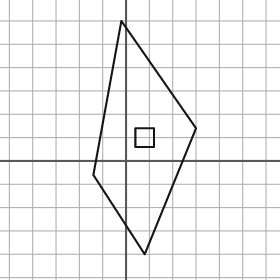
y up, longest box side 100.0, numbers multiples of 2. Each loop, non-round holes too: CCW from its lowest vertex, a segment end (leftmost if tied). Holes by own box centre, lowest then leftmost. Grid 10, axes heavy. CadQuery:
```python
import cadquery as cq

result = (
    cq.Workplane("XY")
    .moveTo(8.0, -40.0)
    .lineTo(30.0, 14.0)
    .lineTo(-2.0, 60.0)
    .lineTo(-14.0, -6.0)
    .close()
    .moveTo(4.0, 6.0)
    .lineTo(12.0, 6.0)
    .lineTo(12.0, 14.0)
    .lineTo(4.0, 14.0)
    .close()
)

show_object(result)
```